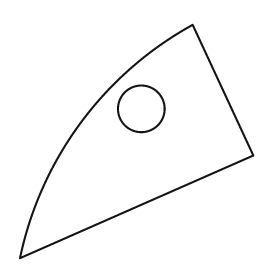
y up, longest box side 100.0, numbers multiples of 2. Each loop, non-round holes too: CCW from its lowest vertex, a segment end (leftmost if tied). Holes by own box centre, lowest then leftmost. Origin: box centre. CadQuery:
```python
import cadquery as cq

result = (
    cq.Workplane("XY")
    .moveTo(-50.0, -50.0)
    .lineTo(50.0, -6.0)
    .lineTo(24.0, 50.0)
    .threePointArc((-24.0, 8.0), (-50.0, -50.0))
    .close()
    .moveTo(2.0, 14.0)
    .circle(10.0)
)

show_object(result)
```